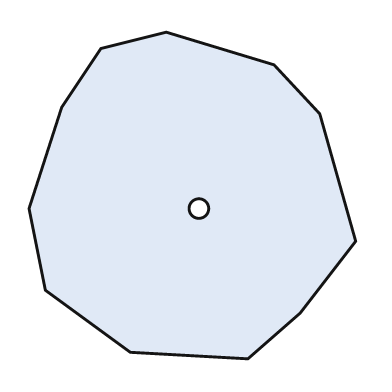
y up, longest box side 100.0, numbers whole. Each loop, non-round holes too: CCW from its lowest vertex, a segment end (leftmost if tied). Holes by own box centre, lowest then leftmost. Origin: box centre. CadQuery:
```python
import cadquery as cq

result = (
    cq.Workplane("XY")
    .moveTo(17.0, -50.0)
    .lineTo(33.0, -36.0)
    .lineTo(50.0, -14.0)
    .lineTo(39.0, 25.0)
    .lineTo(25.0, 40.0)
    .lineTo(-8.0, 50.0)
    .lineTo(-28.0, 45.0)
    .lineTo(-40.0, 27.0)
    .lineTo(-50.0, -4.0)
    .lineTo(-45.0, -29.0)
    .lineTo(-19.0, -48.0)
    .close()
    .moveTo(2.0, -4.0)
    .circle(3.0)
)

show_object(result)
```